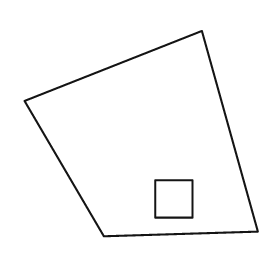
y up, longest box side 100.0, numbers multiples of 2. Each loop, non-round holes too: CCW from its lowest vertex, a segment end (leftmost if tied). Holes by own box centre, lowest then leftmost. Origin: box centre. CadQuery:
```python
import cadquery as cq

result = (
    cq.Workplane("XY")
    .moveTo(-16.0, -44.0)
    .lineTo(50.0, -42.0)
    .lineTo(26.0, 44.0)
    .lineTo(-50.0, 14.0)
    .close()
    .moveTo(6.0, -36.0)
    .lineTo(22.0, -36.0)
    .lineTo(22.0, -20.0)
    .lineTo(6.0, -20.0)
    .close()
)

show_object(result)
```